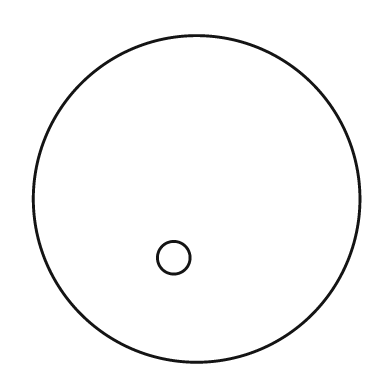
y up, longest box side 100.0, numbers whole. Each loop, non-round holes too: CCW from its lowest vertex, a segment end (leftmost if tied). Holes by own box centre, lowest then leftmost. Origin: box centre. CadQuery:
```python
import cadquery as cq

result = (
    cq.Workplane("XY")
    .moveTo(0.0, 0.0)
    .circle(50.0)
    .moveTo(-7.0, -18.0)
    .circle(5.0)
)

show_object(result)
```